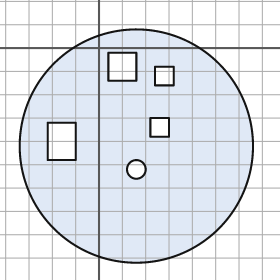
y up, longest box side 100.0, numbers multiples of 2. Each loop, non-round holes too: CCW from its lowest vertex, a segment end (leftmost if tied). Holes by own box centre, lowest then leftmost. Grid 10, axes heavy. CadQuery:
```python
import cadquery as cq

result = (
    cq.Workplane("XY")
    .moveTo(16.0, -42.0)
    .circle(50.0)
    .moveTo(16.0, -52.0)
    .circle(4.0)
    .moveTo(-22.0, -48.0)
    .lineTo(-10.0, -48.0)
    .lineTo(-10.0, -32.0)
    .lineTo(-22.0, -32.0)
    .close()
    .moveTo(22.0, -38.0)
    .lineTo(30.0, -38.0)
    .lineTo(30.0, -30.0)
    .lineTo(22.0, -30.0)
    .close()
    .moveTo(24.0, -16.0)
    .lineTo(32.0, -16.0)
    .lineTo(32.0, -8.0)
    .lineTo(24.0, -8.0)
    .close()
    .moveTo(4.0, -14.0)
    .lineTo(16.0, -14.0)
    .lineTo(16.0, -2.0)
    .lineTo(4.0, -2.0)
    .close()
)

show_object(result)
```